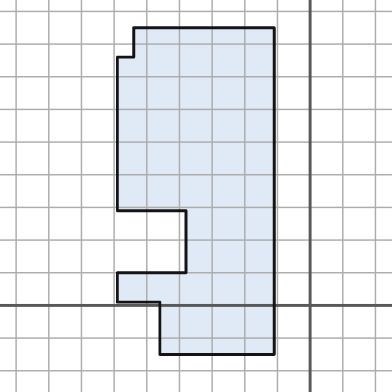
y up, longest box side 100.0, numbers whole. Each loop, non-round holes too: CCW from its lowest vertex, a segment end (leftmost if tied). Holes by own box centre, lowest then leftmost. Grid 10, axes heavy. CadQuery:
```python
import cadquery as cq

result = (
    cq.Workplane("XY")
    .moveTo(-46.0, -15.0)
    .lineTo(-11.0, -15.0)
    .lineTo(-11.0, 85.0)
    .lineTo(-54.0, 85.0)
    .lineTo(-54.0, 76.0)
    .lineTo(-59.0, 76.0)
    .lineTo(-59.0, 29.0)
    .lineTo(-38.0, 29.0)
    .lineTo(-38.0, 10.0)
    .lineTo(-59.0, 10.0)
    .lineTo(-59.0, 1.0)
    .lineTo(-46.0, 1.0)
    .close()
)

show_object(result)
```